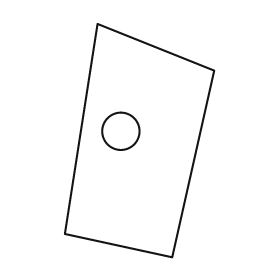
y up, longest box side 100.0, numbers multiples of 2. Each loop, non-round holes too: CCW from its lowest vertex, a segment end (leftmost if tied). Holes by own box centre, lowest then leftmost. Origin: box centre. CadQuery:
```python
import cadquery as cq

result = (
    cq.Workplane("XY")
    .moveTo(14.0, -50.0)
    .lineTo(32.0, 30.0)
    .lineTo(-18.0, 50.0)
    .lineTo(-32.0, -40.0)
    .close()
    .moveTo(-8.0, 4.0)
    .circle(8.0)
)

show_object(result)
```